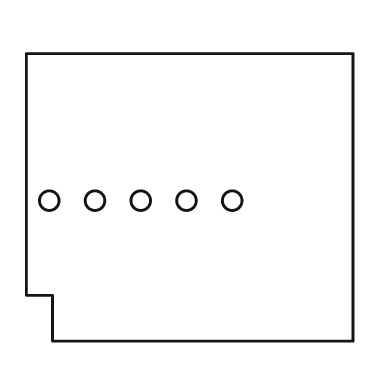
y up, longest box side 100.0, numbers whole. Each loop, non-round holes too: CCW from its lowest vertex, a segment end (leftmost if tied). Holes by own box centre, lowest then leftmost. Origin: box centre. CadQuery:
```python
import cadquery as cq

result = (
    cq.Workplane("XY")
    .moveTo(-42.0, -44.0)
    .lineTo(50.0, -44.0)
    .lineTo(50.0, 44.0)
    .lineTo(-50.0, 44.0)
    .lineTo(-50.0, -30.0)
    .lineTo(-42.0, -30.0)
    .close()
    .moveTo(-43.0, -1.0)
    .circle(3.0)
    .moveTo(-29.0, -1.0)
    .circle(3.0)
    .moveTo(-15.0, -1.0)
    .circle(3.0)
    .moveTo(-1.0, -1.0)
    .circle(3.0)
    .moveTo(13.0, -1.0)
    .circle(3.0)
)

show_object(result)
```